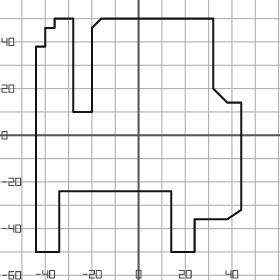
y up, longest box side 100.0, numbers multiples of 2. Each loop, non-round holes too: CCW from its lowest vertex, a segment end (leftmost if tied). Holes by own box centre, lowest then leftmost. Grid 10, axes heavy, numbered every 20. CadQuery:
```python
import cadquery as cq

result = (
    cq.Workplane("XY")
    .moveTo(-44.0, -50.0)
    .lineTo(-34.0, -50.0)
    .lineTo(-34.0, -24.0)
    .lineTo(14.0, -24.0)
    .lineTo(14.0, -50.0)
    .lineTo(24.0, -50.0)
    .lineTo(24.0, -36.0)
    .lineTo(38.0, -36.0)
    .lineTo(44.0, -32.0)
    .lineTo(44.0, 14.0)
    .lineTo(38.0, 14.0)
    .lineTo(32.0, 20.0)
    .lineTo(32.0, 50.0)
    .lineTo(-16.0, 50.0)
    .lineTo(-20.0, 46.0)
    .lineTo(-20.0, 10.0)
    .lineTo(-28.0, 10.0)
    .lineTo(-28.0, 50.0)
    .lineTo(-36.0, 50.0)
    .lineTo(-36.0, 46.0)
    .lineTo(-40.0, 46.0)
    .lineTo(-40.0, 38.0)
    .lineTo(-44.0, 38.0)
    .close()
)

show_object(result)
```